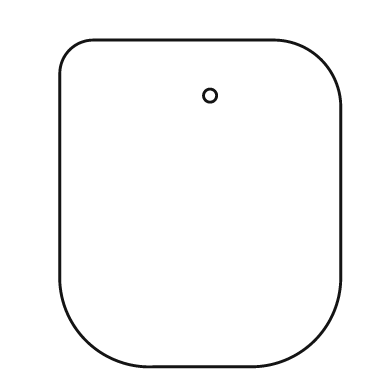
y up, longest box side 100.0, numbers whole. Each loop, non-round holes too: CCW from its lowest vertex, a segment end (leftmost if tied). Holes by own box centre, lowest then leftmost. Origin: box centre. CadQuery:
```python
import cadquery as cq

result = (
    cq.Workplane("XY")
    .moveTo(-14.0, -50.0)
    .lineTo(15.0, -50.0)
    .threePointArc((35.0, -42.0), (43.0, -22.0))
    .lineTo(43.0, 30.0)
    .threePointArc((37.0, 44.0), (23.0, 50.0))
    .lineTo(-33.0, 50.0)
    .threePointArc((-40.0, 47.0), (-43.0, 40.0))
    .lineTo(-43.0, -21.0)
    .threePointArc((-35.0, -42.0), (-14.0, -50.0))
    .close()
    .moveTo(3.0, 33.0)
    .circle(2.0)
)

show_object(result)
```